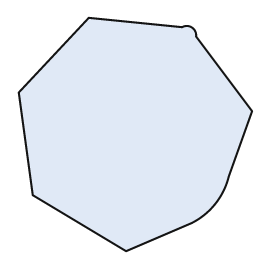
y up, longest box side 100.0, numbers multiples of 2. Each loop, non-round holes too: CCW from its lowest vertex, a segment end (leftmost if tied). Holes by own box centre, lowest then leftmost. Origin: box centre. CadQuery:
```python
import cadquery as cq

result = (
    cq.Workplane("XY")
    .moveTo(-4.0, -50.0)
    .lineTo(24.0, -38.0)
    .threePointArc((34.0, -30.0), (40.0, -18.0))
    .lineTo(50.0, 10.0)
    .lineTo(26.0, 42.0)
    .threePointArc((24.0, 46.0), (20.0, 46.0))
    .lineTo(-20.0, 50.0)
    .lineTo(-50.0, 18.0)
    .lineTo(-44.0, -26.0)
    .close()
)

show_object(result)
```